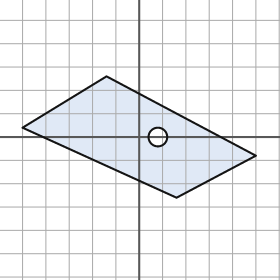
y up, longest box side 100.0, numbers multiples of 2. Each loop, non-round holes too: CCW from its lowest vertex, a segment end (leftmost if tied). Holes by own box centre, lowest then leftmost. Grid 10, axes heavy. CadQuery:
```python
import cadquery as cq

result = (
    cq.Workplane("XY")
    .moveTo(16.0, -26.0)
    .lineTo(50.0, -8.0)
    .lineTo(-14.0, 26.0)
    .lineTo(-50.0, 4.0)
    .close()
    .moveTo(8.0, 0.0)
    .circle(4.0)
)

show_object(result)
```